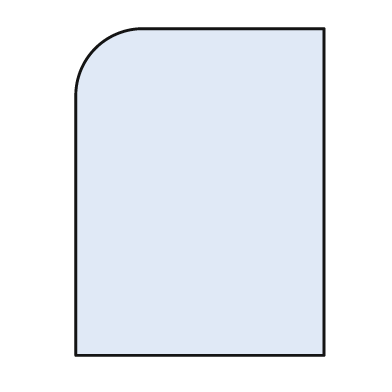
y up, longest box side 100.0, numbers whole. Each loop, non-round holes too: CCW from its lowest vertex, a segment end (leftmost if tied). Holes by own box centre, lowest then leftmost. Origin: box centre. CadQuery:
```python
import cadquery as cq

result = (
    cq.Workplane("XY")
    .moveTo(-38.0, -50.0)
    .lineTo(38.0, -50.0)
    .lineTo(38.0, 50.0)
    .lineTo(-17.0, 50.0)
    .threePointArc((-32.0, 44.0), (-38.0, 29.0))
    .close()
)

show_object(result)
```